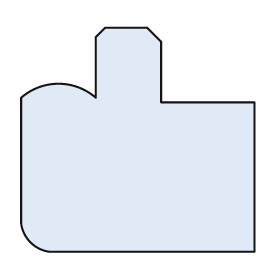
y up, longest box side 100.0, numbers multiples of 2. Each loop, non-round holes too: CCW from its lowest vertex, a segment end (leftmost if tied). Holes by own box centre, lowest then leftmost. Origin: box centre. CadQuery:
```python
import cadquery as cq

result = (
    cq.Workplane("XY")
    .moveTo(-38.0, -48.0)
    .lineTo(50.0, -48.0)
    .lineTo(50.0, 16.0)
    .lineTo(10.0, 16.0)
    .lineTo(10.0, 42.0)
    .lineTo(4.0, 48.0)
    .lineTo(-14.0, 48.0)
    .lineTo(-18.0, 44.0)
    .lineTo(-18.0, 18.0)
    .threePointArc((-34.0, 24.0), (-50.0, 18.0))
    .lineTo(-50.0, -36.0)
    .threePointArc((-46.0, -44.0), (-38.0, -48.0))
    .close()
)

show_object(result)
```